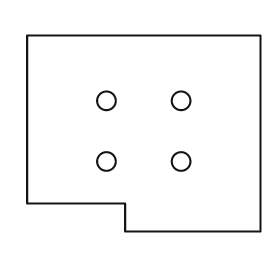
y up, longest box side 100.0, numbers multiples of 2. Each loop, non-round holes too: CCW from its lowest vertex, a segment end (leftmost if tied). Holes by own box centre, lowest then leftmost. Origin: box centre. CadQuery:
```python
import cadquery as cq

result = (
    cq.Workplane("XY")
    .moveTo(-8.0, -42.0)
    .lineTo(50.0, -42.0)
    .lineTo(50.0, 42.0)
    .lineTo(-50.0, 42.0)
    .lineTo(-50.0, -30.0)
    .lineTo(-8.0, -30.0)
    .close()
    .moveTo(-16.0, -12.0)
    .circle(4.0)
    .moveTo(16.0, -12.0)
    .circle(4.0)
    .moveTo(-16.0, 14.0)
    .circle(4.0)
    .moveTo(16.0, 14.0)
    .circle(4.0)
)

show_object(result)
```